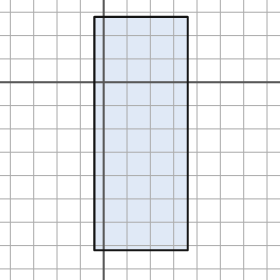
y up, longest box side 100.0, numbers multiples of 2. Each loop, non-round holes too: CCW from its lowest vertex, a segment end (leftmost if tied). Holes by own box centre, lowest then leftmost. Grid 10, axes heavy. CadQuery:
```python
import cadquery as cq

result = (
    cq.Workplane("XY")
    .moveTo(-4.0, -72.0)
    .lineTo(36.0, -72.0)
    .lineTo(36.0, 28.0)
    .lineTo(-4.0, 28.0)
    .close()
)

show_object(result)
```